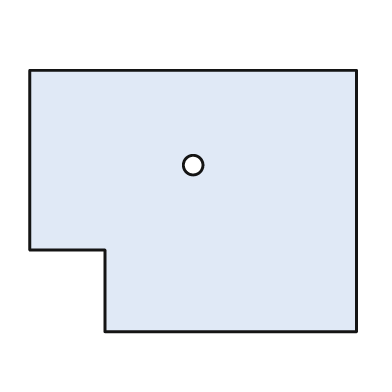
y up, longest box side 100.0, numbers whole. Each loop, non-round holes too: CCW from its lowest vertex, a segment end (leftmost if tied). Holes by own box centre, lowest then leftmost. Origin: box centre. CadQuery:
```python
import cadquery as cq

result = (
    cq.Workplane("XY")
    .moveTo(-27.0, -40.0)
    .lineTo(50.0, -40.0)
    .lineTo(50.0, 40.0)
    .lineTo(-50.0, 40.0)
    .lineTo(-50.0, -15.0)
    .lineTo(-27.0, -15.0)
    .close()
    .moveTo(0.0, 11.0)
    .circle(3.0)
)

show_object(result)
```